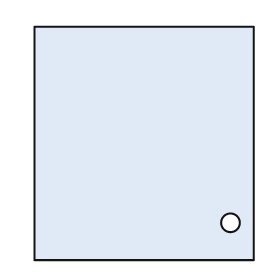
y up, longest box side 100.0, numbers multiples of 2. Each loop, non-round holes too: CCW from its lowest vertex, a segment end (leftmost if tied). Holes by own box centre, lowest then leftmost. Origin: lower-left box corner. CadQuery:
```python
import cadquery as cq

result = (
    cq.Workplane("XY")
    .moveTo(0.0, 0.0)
    .lineTo(94.0, 0.0)
    .lineTo(94.0, 100.0)
    .lineTo(0.0, 100.0)
    .close()
    .moveTo(84.0, 16.0)
    .circle(4.0)
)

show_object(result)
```